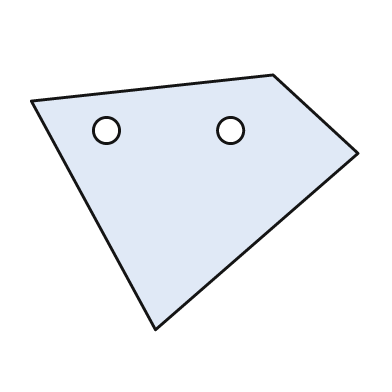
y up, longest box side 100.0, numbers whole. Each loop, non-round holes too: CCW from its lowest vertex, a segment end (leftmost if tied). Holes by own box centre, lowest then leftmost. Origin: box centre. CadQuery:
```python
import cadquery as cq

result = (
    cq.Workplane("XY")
    .moveTo(-12.0, -39.0)
    .lineTo(50.0, 15.0)
    .lineTo(24.0, 39.0)
    .lineTo(-50.0, 31.0)
    .close()
    .moveTo(-27.0, 22.0)
    .circle(4.0)
    .moveTo(11.0, 22.0)
    .circle(4.0)
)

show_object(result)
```